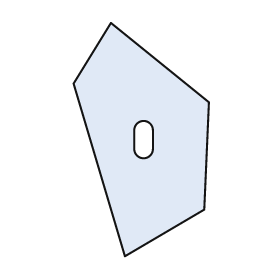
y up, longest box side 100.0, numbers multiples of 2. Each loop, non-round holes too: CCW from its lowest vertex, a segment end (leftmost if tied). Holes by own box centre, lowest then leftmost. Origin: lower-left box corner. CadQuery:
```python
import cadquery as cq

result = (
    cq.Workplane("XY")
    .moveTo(22.0, 0.0)
    .lineTo(56.0, 20.0)
    .lineTo(58.0, 66.0)
    .lineTo(16.0, 100.0)
    .lineTo(0.0, 74.0)
    .close()
    .moveTo(26.0, 46.0)
    .threePointArc((30.0, 42.0), (34.0, 46.0))
    .lineTo(34.0, 54.0)
    .threePointArc((30.0, 58.0), (26.0, 54.0))
    .close()
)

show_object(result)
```